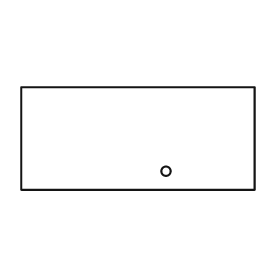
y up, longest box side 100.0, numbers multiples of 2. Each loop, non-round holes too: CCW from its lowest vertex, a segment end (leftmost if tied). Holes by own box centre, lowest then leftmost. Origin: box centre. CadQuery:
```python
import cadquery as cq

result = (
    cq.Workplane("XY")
    .moveTo(-50.0, -22.0)
    .lineTo(50.0, -22.0)
    .lineTo(50.0, 22.0)
    .lineTo(-50.0, 22.0)
    .close()
    .moveTo(12.0, -14.0)
    .circle(2.0)
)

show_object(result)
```